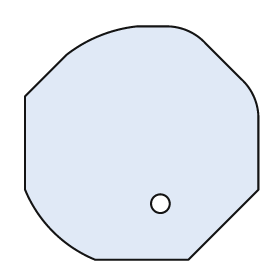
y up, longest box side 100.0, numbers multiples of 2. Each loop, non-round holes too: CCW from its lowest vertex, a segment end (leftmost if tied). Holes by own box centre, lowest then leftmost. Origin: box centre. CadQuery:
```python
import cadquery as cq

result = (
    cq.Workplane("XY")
    .moveTo(-20.0, -50.0)
    .lineTo(20.0, -50.0)
    .lineTo(50.0, -20.0)
    .lineTo(50.0, 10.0)
    .threePointArc((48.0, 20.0), (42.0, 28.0))
    .lineTo(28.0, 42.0)
    .threePointArc((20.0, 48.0), (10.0, 50.0))
    .lineTo(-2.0, 50.0)
    .threePointArc((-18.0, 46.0), (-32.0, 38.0))
    .lineTo(-50.0, 20.0)
    .lineTo(-50.0, -20.0)
    .threePointArc((-38.0, -38.0), (-20.0, -50.0))
    .close()
    .moveTo(8.0, -26.0)
    .circle(4.0)
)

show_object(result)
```